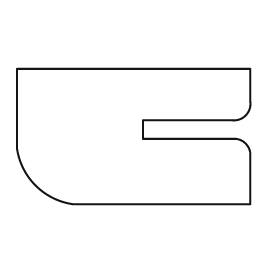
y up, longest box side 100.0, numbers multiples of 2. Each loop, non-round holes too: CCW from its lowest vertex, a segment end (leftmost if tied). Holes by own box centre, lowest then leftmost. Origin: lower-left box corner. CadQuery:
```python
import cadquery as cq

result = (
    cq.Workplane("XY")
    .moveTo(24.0, 0.0)
    .lineTo(100.0, 0.0)
    .lineTo(100.0, 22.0)
    .threePointArc((98.0, 26.0), (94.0, 28.0))
    .lineTo(54.0, 28.0)
    .lineTo(54.0, 36.0)
    .lineTo(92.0, 36.0)
    .threePointArc((98.0, 38.0), (100.0, 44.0))
    .lineTo(100.0, 58.0)
    .lineTo(0.0, 58.0)
    .lineTo(0.0, 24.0)
    .threePointArc((8.0, 8.0), (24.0, 0.0))
    .close()
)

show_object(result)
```